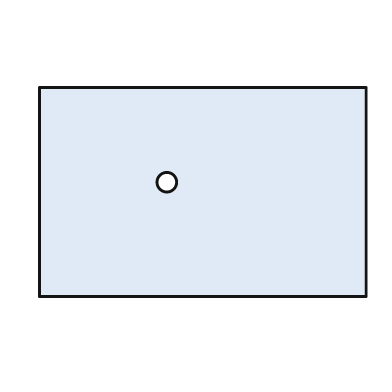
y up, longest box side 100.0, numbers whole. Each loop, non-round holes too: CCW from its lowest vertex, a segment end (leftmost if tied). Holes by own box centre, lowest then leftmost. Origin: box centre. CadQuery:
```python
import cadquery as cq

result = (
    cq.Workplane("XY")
    .moveTo(-50.0, -32.0)
    .lineTo(50.0, -32.0)
    .lineTo(50.0, 32.0)
    .lineTo(-50.0, 32.0)
    .close()
    .moveTo(-11.0, 3.0)
    .circle(3.0)
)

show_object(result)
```